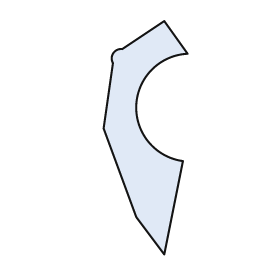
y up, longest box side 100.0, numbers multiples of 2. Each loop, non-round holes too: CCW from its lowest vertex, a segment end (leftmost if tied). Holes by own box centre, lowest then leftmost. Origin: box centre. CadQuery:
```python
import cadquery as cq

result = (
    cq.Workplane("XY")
    .moveTo(8.0, -50.0)
    .lineTo(16.0, -10.0)
    .threePointArc((-4.0, 14.0), (18.0, 36.0))
    .lineTo(8.0, 50.0)
    .lineTo(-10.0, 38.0)
    .threePointArc((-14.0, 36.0), (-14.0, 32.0))
    .lineTo(-18.0, 4.0)
    .lineTo(-4.0, -34.0)
    .close()
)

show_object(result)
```